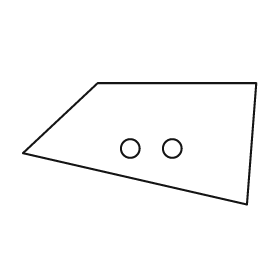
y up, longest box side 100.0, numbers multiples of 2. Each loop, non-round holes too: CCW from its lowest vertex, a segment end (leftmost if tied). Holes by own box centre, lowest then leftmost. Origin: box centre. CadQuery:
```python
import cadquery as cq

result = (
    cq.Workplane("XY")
    .moveTo(46.0, -26.0)
    .lineTo(50.0, 26.0)
    .lineTo(-18.0, 26.0)
    .lineTo(-50.0, -4.0)
    .close()
    .moveTo(-4.0, -2.0)
    .circle(4.0)
    .moveTo(14.0, -2.0)
    .circle(4.0)
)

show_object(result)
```